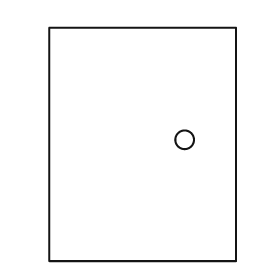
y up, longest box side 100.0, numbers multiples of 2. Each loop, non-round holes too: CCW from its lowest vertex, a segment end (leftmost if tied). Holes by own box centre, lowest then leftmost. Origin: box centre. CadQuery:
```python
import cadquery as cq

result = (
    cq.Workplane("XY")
    .moveTo(-40.0, -50.0)
    .lineTo(40.0, -50.0)
    .lineTo(40.0, 50.0)
    .lineTo(-40.0, 50.0)
    .close()
    .moveTo(18.0, 2.0)
    .circle(4.0)
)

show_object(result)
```